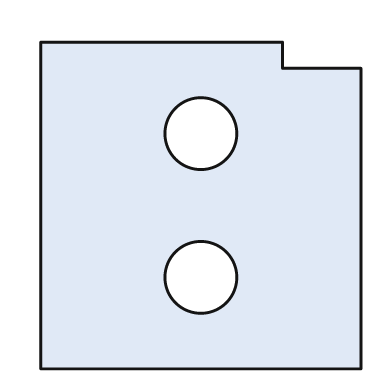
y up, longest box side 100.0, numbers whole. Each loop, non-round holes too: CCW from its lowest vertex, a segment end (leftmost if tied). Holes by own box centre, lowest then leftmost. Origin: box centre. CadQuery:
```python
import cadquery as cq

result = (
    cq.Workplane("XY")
    .moveTo(-49.0, -50.0)
    .lineTo(49.0, -50.0)
    .lineTo(49.0, 42.0)
    .lineTo(25.0, 42.0)
    .lineTo(25.0, 50.0)
    .lineTo(-49.0, 50.0)
    .close()
    .moveTo(0.0, -22.0)
    .circle(11.0)
    .moveTo(0.0, 22.0)
    .circle(11.0)
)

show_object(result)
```